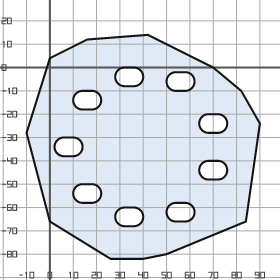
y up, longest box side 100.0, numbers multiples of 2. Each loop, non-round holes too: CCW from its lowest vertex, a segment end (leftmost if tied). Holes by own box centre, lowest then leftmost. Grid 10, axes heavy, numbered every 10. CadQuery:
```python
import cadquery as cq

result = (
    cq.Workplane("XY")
    .moveTo(26.0, -82.0)
    .lineTo(40.0, -82.0)
    .lineTo(50.0, -80.0)
    .lineTo(84.0, -66.0)
    .lineTo(90.0, -24.0)
    .lineTo(82.0, -10.0)
    .lineTo(70.0, 0.0)
    .lineTo(42.0, 14.0)
    .lineTo(16.0, 12.0)
    .lineTo(0.0, 4.0)
    .lineTo(-10.0, -28.0)
    .lineTo(0.0, -66.0)
    .close()
    .moveTo(32.0, -68.0)
    .lineTo(36.0, -68.0)
    .threePointArc((40.0, -64.0), (36.0, -60.0))
    .lineTo(32.0, -60.0)
    .threePointArc((28.0, -64.0), (32.0, -68.0))
    .close()
    .moveTo(54.0, -66.0)
    .lineTo(58.0, -66.0)
    .threePointArc((62.0, -62.0), (58.0, -58.0))
    .lineTo(54.0, -58.0)
    .threePointArc((50.0, -62.0), (54.0, -66.0))
    .close()
    .moveTo(14.0, -58.0)
    .lineTo(18.0, -58.0)
    .threePointArc((22.0, -54.0), (18.0, -50.0))
    .lineTo(14.0, -50.0)
    .threePointArc((10.0, -54.0), (14.0, -58.0))
    .close()
    .moveTo(68.0, -48.0)
    .lineTo(72.0, -48.0)
    .threePointArc((76.0, -44.0), (72.0, -40.0))
    .lineTo(68.0, -40.0)
    .threePointArc((64.0, -44.0), (68.0, -48.0))
    .close()
    .moveTo(6.0, -38.0)
    .lineTo(10.0, -38.0)
    .threePointArc((14.0, -34.0), (10.0, -30.0))
    .lineTo(6.0, -30.0)
    .threePointArc((2.0, -34.0), (6.0, -38.0))
    .close()
    .moveTo(68.0, -28.0)
    .lineTo(72.0, -28.0)
    .threePointArc((76.0, -24.0), (72.0, -20.0))
    .lineTo(68.0, -20.0)
    .threePointArc((64.0, -24.0), (68.0, -28.0))
    .close()
    .moveTo(14.0, -18.0)
    .lineTo(18.0, -18.0)
    .threePointArc((22.0, -14.0), (18.0, -10.0))
    .lineTo(14.0, -10.0)
    .threePointArc((10.0, -14.0), (14.0, -18.0))
    .close()
    .moveTo(54.0, -10.0)
    .lineTo(58.0, -10.0)
    .threePointArc((62.0, -6.0), (58.0, -2.0))
    .lineTo(54.0, -2.0)
    .threePointArc((50.0, -6.0), (54.0, -10.0))
    .close()
    .moveTo(32.0, -8.0)
    .lineTo(36.0, -8.0)
    .threePointArc((40.0, -4.0), (36.0, 0.0))
    .lineTo(32.0, 0.0)
    .threePointArc((28.0, -4.0), (32.0, -8.0))
    .close()
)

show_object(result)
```